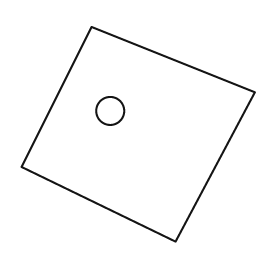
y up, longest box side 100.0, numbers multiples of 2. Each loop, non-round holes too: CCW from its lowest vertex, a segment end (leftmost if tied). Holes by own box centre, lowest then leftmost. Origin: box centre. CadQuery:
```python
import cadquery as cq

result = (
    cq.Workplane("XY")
    .moveTo(16.0, -46.0)
    .lineTo(50.0, 18.0)
    .lineTo(-20.0, 46.0)
    .lineTo(-50.0, -14.0)
    .close()
    .moveTo(-12.0, 10.0)
    .circle(6.0)
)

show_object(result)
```